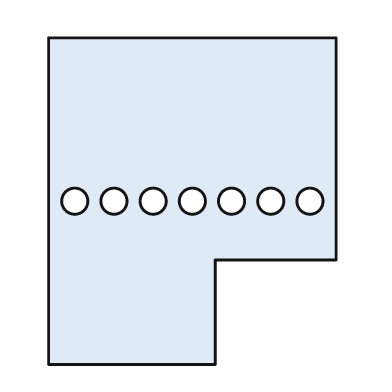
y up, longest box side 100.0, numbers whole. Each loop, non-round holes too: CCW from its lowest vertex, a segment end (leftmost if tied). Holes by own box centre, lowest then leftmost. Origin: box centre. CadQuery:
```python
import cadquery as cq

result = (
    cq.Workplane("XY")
    .moveTo(-44.0, -50.0)
    .lineTo(7.0, -50.0)
    .lineTo(7.0, -18.0)
    .lineTo(44.0, -18.0)
    .lineTo(44.0, 50.0)
    .lineTo(-44.0, 50.0)
    .close()
    .moveTo(-36.0, 0.0)
    .circle(4.0)
    .moveTo(-24.0, 0.0)
    .circle(4.0)
    .moveTo(-12.0, 0.0)
    .circle(4.0)
    .moveTo(0.0, 0.0)
    .circle(4.0)
    .moveTo(12.0, 0.0)
    .circle(4.0)
    .moveTo(24.0, 0.0)
    .circle(4.0)
    .moveTo(36.0, 0.0)
    .circle(4.0)
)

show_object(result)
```